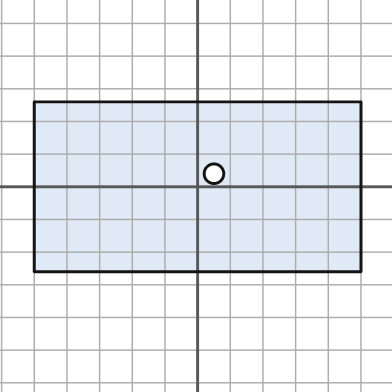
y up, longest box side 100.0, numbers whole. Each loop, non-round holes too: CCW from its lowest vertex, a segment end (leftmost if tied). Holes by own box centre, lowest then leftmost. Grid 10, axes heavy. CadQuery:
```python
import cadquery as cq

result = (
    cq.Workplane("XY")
    .moveTo(-50.0, -26.0)
    .lineTo(50.0, -26.0)
    .lineTo(50.0, 26.0)
    .lineTo(-50.0, 26.0)
    .close()
    .moveTo(5.0, 4.0)
    .circle(3.0)
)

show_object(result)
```